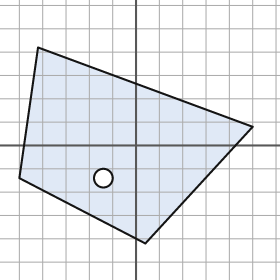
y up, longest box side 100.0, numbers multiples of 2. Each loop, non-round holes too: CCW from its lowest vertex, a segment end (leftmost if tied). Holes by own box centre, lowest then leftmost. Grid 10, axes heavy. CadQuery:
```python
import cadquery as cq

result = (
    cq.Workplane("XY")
    .moveTo(4.0, -42.0)
    .lineTo(50.0, 8.0)
    .lineTo(-42.0, 42.0)
    .lineTo(-50.0, -14.0)
    .close()
    .moveTo(-14.0, -14.0)
    .circle(4.0)
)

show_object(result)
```